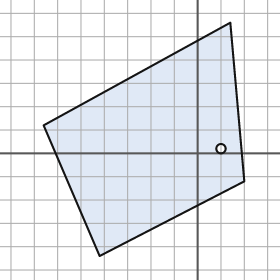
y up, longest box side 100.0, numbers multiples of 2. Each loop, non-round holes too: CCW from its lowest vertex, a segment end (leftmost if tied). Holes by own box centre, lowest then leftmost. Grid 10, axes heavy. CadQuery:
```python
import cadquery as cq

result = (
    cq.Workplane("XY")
    .moveTo(-42.0, -44.0)
    .lineTo(20.0, -12.0)
    .lineTo(14.0, 56.0)
    .lineTo(-66.0, 12.0)
    .close()
    .moveTo(10.0, 2.0)
    .circle(2.0)
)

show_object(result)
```